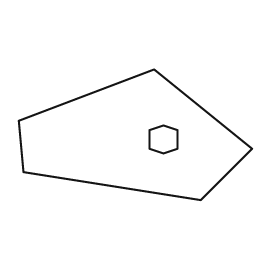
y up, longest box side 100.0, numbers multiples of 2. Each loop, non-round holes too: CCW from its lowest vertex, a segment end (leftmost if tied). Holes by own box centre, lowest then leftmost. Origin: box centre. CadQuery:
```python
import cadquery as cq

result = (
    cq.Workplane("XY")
    .moveTo(28.0, -28.0)
    .lineTo(50.0, -6.0)
    .lineTo(8.0, 28.0)
    .lineTo(-50.0, 6.0)
    .lineTo(-48.0, -16.0)
    .close()
    .moveTo(12.0, -8.0)
    .lineTo(18.0, -6.0)
    .lineTo(18.0, 2.0)
    .lineTo(12.0, 4.0)
    .lineTo(6.0, 2.0)
    .lineTo(6.0, -6.0)
    .close()
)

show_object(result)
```